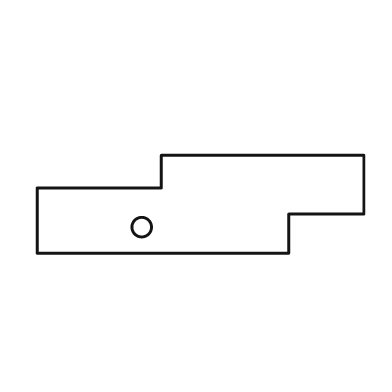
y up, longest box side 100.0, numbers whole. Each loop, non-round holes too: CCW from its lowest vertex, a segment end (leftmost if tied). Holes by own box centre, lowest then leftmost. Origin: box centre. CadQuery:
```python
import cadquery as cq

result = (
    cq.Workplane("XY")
    .moveTo(-50.0, -15.0)
    .lineTo(27.0, -15.0)
    .lineTo(27.0, -3.0)
    .lineTo(50.0, -3.0)
    .lineTo(50.0, 15.0)
    .lineTo(-12.0, 15.0)
    .lineTo(-12.0, 5.0)
    .lineTo(-50.0, 5.0)
    .close()
    .moveTo(-18.0, -7.0)
    .circle(3.0)
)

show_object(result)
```